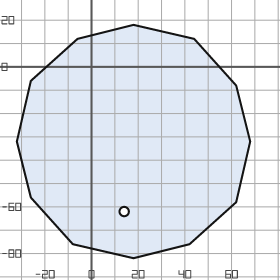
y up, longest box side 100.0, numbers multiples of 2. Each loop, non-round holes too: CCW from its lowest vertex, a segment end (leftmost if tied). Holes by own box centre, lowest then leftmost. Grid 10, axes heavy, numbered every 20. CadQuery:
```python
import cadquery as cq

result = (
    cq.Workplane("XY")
    .moveTo(18.0, -82.0)
    .lineTo(42.0, -76.0)
    .lineTo(62.0, -58.0)
    .lineTo(68.0, -32.0)
    .lineTo(62.0, -8.0)
    .lineTo(44.0, 12.0)
    .lineTo(18.0, 18.0)
    .lineTo(-6.0, 12.0)
    .lineTo(-26.0, -6.0)
    .lineTo(-32.0, -32.0)
    .lineTo(-26.0, -56.0)
    .lineTo(-8.0, -76.0)
    .close()
    .moveTo(14.0, -62.0)
    .circle(2.0)
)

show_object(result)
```